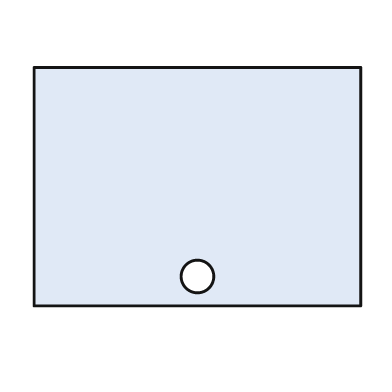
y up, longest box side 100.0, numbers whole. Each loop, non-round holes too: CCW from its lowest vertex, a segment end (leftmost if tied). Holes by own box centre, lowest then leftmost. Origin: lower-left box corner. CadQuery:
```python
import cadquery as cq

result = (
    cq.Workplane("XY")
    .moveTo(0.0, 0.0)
    .lineTo(100.0, 0.0)
    .lineTo(100.0, 73.0)
    .lineTo(0.0, 73.0)
    .close()
    .moveTo(50.0, 9.0)
    .circle(5.0)
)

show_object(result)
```